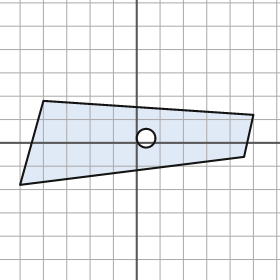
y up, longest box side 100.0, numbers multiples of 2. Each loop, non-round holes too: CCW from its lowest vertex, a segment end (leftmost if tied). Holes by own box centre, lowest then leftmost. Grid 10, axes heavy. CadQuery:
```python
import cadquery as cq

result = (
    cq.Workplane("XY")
    .moveTo(-50.0, -18.0)
    .lineTo(46.0, -6.0)
    .lineTo(50.0, 12.0)
    .lineTo(-40.0, 18.0)
    .close()
    .moveTo(4.0, 2.0)
    .circle(4.0)
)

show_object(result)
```